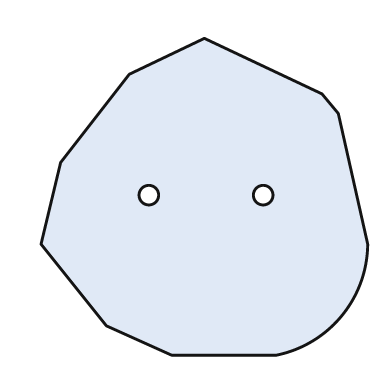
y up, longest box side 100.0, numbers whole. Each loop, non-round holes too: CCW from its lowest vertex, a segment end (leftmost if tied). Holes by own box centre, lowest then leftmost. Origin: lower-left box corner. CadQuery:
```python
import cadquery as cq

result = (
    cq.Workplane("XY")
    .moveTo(40.0, 0.0)
    .lineTo(72.0, 0.0)
    .threePointArc((92.0, 12.0), (100.0, 34.0))
    .lineTo(91.0, 74.0)
    .lineTo(86.0, 80.0)
    .lineTo(50.0, 97.0)
    .lineTo(27.0, 86.0)
    .lineTo(6.0, 59.0)
    .lineTo(0.0, 34.0)
    .lineTo(20.0, 9.0)
    .close()
    .moveTo(33.0, 49.0)
    .circle(3.0)
    .moveTo(68.0, 49.0)
    .circle(3.0)
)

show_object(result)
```